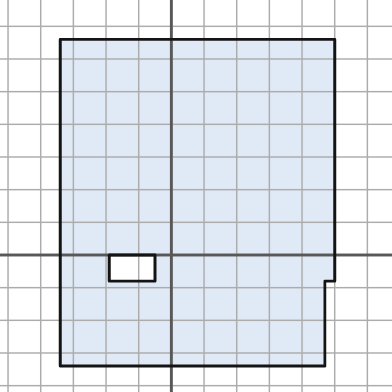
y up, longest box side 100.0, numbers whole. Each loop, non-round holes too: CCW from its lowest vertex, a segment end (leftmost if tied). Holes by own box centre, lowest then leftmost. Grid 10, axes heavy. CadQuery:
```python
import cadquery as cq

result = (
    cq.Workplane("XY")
    .moveTo(-34.0, -34.0)
    .lineTo(47.0, -34.0)
    .lineTo(47.0, -8.0)
    .lineTo(50.0, -8.0)
    .lineTo(50.0, 66.0)
    .lineTo(-34.0, 66.0)
    .close()
    .moveTo(-19.0, -8.0)
    .lineTo(-5.0, -8.0)
    .lineTo(-5.0, 0.0)
    .lineTo(-19.0, 0.0)
    .close()
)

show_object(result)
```